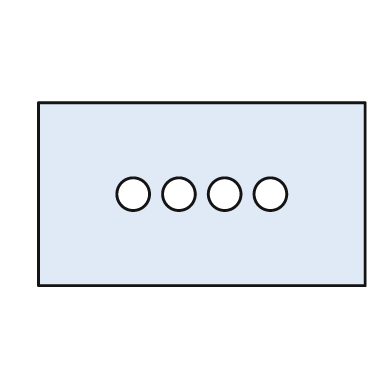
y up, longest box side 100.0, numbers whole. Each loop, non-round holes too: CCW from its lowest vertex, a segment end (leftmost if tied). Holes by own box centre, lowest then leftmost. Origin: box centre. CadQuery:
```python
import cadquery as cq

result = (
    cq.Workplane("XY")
    .moveTo(-50.0, -28.0)
    .lineTo(50.0, -28.0)
    .lineTo(50.0, 28.0)
    .lineTo(-50.0, 28.0)
    .close()
    .moveTo(-21.0, 0.0)
    .circle(5.0)
    .moveTo(-7.0, 0.0)
    .circle(5.0)
    .moveTo(7.0, 0.0)
    .circle(5.0)
    .moveTo(21.0, 0.0)
    .circle(5.0)
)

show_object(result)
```